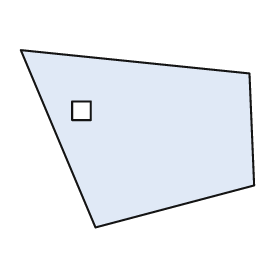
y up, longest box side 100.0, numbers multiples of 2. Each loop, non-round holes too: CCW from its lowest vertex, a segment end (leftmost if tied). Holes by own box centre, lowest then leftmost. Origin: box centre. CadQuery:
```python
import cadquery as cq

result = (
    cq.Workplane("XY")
    .moveTo(-18.0, -38.0)
    .lineTo(50.0, -20.0)
    .lineTo(48.0, 28.0)
    .lineTo(-50.0, 38.0)
    .close()
    .moveTo(-28.0, 8.0)
    .lineTo(-20.0, 8.0)
    .lineTo(-20.0, 16.0)
    .lineTo(-28.0, 16.0)
    .close()
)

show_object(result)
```